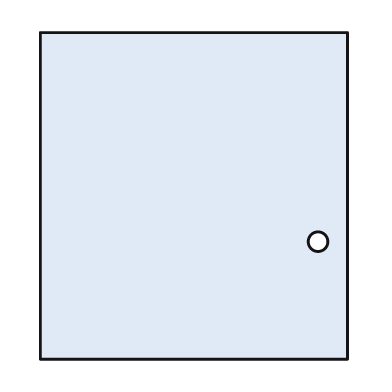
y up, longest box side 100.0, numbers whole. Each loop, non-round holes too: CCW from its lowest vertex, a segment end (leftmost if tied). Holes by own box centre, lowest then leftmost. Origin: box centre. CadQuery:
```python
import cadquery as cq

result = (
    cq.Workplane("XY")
    .moveTo(-47.0, -50.0)
    .lineTo(47.0, -50.0)
    .lineTo(47.0, 50.0)
    .lineTo(-47.0, 50.0)
    .close()
    .moveTo(38.0, -14.0)
    .circle(3.0)
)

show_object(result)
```